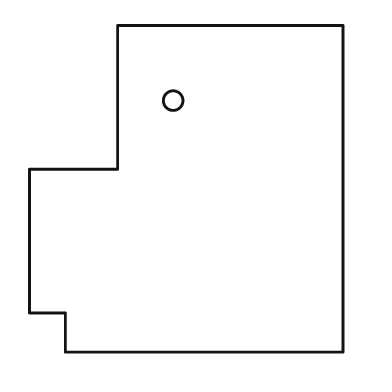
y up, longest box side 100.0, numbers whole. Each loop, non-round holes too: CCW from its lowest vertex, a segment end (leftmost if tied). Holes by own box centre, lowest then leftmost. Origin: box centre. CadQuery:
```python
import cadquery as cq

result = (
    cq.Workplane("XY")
    .moveTo(-37.0, -50.0)
    .lineTo(48.0, -50.0)
    .lineTo(48.0, 50.0)
    .lineTo(-21.0, 50.0)
    .lineTo(-21.0, 6.0)
    .lineTo(-48.0, 6.0)
    .lineTo(-48.0, -38.0)
    .lineTo(-37.0, -38.0)
    .close()
    .moveTo(-4.0, 27.0)
    .circle(3.0)
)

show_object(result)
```